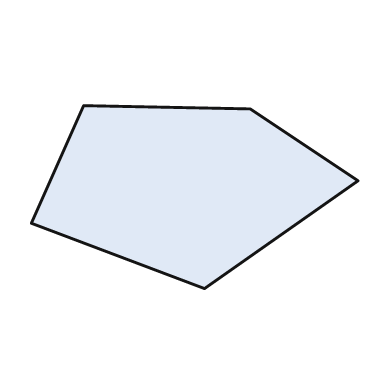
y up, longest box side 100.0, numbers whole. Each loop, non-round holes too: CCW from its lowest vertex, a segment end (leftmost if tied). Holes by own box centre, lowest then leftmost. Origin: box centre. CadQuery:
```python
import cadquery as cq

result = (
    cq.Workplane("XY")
    .moveTo(3.0, -28.0)
    .lineTo(50.0, 5.0)
    .lineTo(17.0, 27.0)
    .lineTo(-34.0, 28.0)
    .lineTo(-50.0, -8.0)
    .close()
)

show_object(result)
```